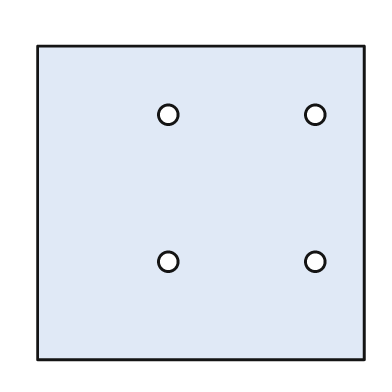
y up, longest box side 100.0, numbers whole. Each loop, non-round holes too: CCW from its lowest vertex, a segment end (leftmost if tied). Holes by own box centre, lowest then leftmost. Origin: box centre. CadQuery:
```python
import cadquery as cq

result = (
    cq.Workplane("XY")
    .moveTo(-50.0, -48.0)
    .lineTo(50.0, -48.0)
    .lineTo(50.0, 48.0)
    .lineTo(-50.0, 48.0)
    .close()
    .moveTo(-10.0, -18.0)
    .circle(3.0)
    .moveTo(35.0, -18.0)
    .circle(3.0)
    .moveTo(-10.0, 27.0)
    .circle(3.0)
    .moveTo(35.0, 27.0)
    .circle(3.0)
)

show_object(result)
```